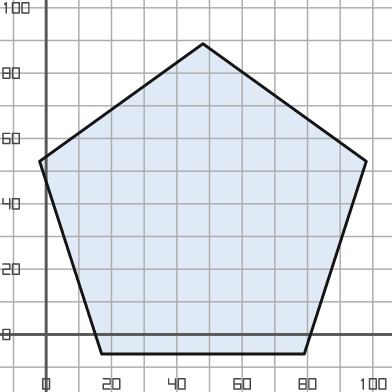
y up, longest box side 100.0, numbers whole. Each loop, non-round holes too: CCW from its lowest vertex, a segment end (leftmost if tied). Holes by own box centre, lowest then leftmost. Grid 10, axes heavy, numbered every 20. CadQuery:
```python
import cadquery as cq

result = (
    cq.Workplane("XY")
    .moveTo(17.0, -6.0)
    .lineTo(79.0, -6.0)
    .lineTo(98.0, 53.0)
    .lineTo(48.0, 89.0)
    .lineTo(-2.0, 53.0)
    .close()
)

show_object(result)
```